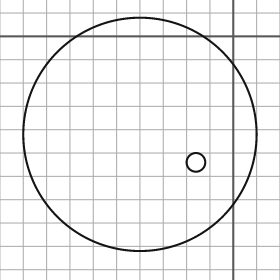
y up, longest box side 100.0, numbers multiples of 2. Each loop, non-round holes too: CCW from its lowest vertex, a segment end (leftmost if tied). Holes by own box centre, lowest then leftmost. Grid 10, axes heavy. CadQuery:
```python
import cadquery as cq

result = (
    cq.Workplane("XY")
    .moveTo(-40.0, -42.0)
    .circle(50.0)
    .moveTo(-16.0, -54.0)
    .circle(4.0)
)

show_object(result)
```